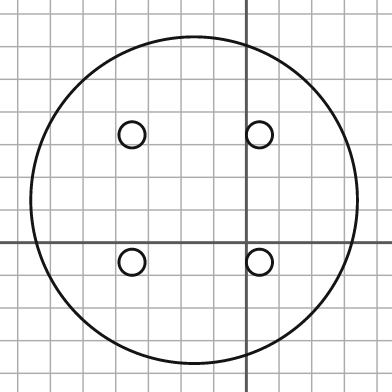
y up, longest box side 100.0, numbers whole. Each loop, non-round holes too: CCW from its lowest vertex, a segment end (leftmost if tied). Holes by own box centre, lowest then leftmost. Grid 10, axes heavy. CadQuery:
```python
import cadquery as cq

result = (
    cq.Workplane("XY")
    .moveTo(-16.0, 13.0)
    .circle(50.0)
    .moveTo(-35.0, -6.0)
    .circle(4.0)
    .moveTo(4.0, -6.0)
    .circle(4.0)
    .moveTo(-35.0, 33.0)
    .circle(4.0)
    .moveTo(4.0, 33.0)
    .circle(4.0)
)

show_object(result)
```